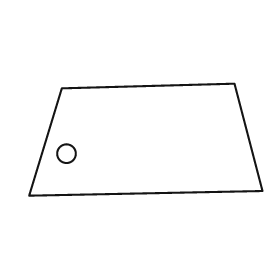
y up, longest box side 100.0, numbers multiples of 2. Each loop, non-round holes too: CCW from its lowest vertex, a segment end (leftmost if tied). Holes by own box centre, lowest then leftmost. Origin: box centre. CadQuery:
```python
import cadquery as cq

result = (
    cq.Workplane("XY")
    .moveTo(-50.0, -24.0)
    .lineTo(50.0, -22.0)
    .lineTo(38.0, 24.0)
    .lineTo(-36.0, 22.0)
    .close()
    .moveTo(-34.0, -6.0)
    .circle(4.0)
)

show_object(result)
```